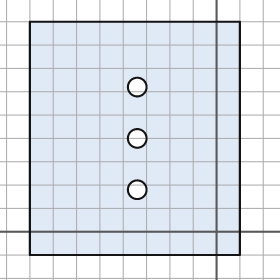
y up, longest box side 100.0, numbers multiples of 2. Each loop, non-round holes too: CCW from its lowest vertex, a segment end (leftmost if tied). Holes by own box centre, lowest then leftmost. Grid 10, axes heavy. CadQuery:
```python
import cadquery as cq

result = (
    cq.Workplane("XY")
    .moveTo(-80.0, -10.0)
    .lineTo(10.0, -10.0)
    .lineTo(10.0, 90.0)
    .lineTo(-80.0, 90.0)
    .close()
    .moveTo(-34.0, 18.0)
    .circle(4.0)
    .moveTo(-34.0, 40.0)
    .circle(4.0)
    .moveTo(-34.0, 62.0)
    .circle(4.0)
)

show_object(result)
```